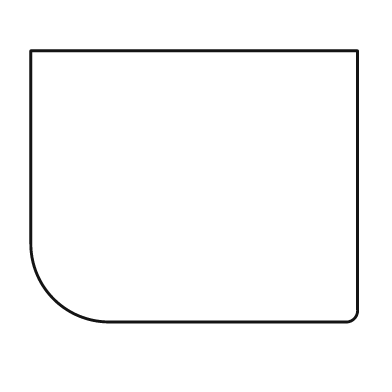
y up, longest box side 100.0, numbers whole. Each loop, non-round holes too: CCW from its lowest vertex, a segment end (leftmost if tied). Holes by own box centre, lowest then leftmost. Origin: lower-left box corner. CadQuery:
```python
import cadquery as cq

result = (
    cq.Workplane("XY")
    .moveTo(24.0, 0.0)
    .lineTo(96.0, 0.0)
    .threePointArc((99.0, 1.0), (100.0, 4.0))
    .lineTo(100.0, 83.0)
    .lineTo(0.0, 83.0)
    .lineTo(0.0, 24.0)
    .threePointArc((7.0, 7.0), (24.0, 0.0))
    .close()
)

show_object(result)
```